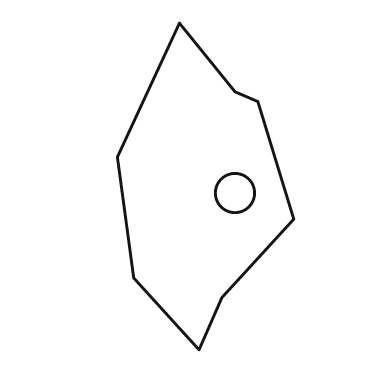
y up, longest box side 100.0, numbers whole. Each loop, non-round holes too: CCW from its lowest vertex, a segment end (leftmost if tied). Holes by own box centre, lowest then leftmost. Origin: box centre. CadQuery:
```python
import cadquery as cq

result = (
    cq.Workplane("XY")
    .moveTo(-2.0, -50.0)
    .lineTo(5.0, -34.0)
    .lineTo(27.0, -10.0)
    .lineTo(16.0, 26.0)
    .lineTo(9.0, 29.0)
    .lineTo(-8.0, 50.0)
    .lineTo(-27.0, 9.0)
    .lineTo(-22.0, -28.0)
    .close()
    .moveTo(9.0, -2.0)
    .circle(6.0)
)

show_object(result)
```